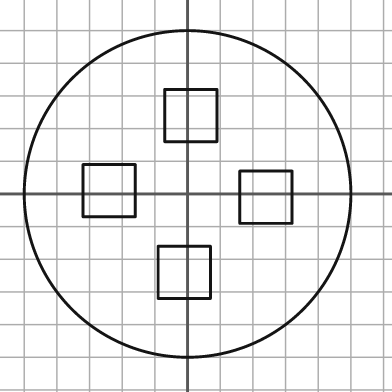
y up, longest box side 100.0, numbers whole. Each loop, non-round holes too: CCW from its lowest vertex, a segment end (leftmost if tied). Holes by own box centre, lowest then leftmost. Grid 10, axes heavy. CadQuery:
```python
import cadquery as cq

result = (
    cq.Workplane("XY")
    .moveTo(0.0, 0.0)
    .circle(50.0)
    .moveTo(-9.0, -32.0)
    .lineTo(7.0, -32.0)
    .lineTo(7.0, -16.0)
    .lineTo(-9.0, -16.0)
    .close()
    .moveTo(16.0, -9.0)
    .lineTo(32.0, -9.0)
    .lineTo(32.0, 7.0)
    .lineTo(16.0, 7.0)
    .close()
    .moveTo(-32.0, -7.0)
    .lineTo(-16.0, -7.0)
    .lineTo(-16.0, 9.0)
    .lineTo(-32.0, 9.0)
    .close()
    .moveTo(-7.0, 16.0)
    .lineTo(9.0, 16.0)
    .lineTo(9.0, 32.0)
    .lineTo(-7.0, 32.0)
    .close()
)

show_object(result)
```